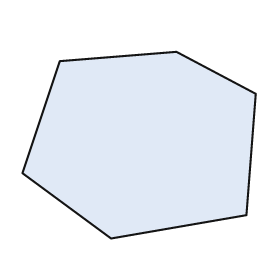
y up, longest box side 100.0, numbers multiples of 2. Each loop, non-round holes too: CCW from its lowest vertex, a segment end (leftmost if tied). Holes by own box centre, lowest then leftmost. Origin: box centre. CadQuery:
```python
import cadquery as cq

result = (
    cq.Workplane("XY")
    .moveTo(-12.0, -40.0)
    .lineTo(46.0, -30.0)
    .lineTo(50.0, 22.0)
    .lineTo(16.0, 40.0)
    .lineTo(-34.0, 36.0)
    .lineTo(-50.0, -12.0)
    .close()
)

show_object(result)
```